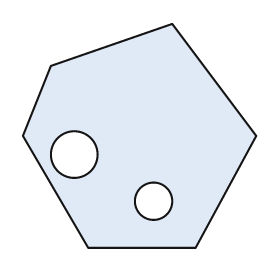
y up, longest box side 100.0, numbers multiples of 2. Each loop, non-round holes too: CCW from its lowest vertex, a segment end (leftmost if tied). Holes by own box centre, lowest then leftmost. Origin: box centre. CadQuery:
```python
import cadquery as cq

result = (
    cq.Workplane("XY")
    .moveTo(-22.0, -48.0)
    .lineTo(24.0, -48.0)
    .lineTo(50.0, 0.0)
    .lineTo(14.0, 48.0)
    .lineTo(-38.0, 30.0)
    .lineTo(-50.0, 0.0)
    .close()
    .moveTo(6.0, -28.0)
    .circle(8.0)
    .moveTo(-28.0, -8.0)
    .circle(10.0)
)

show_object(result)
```